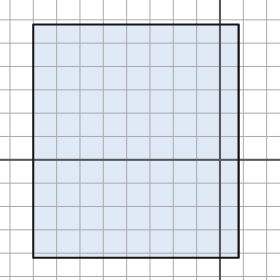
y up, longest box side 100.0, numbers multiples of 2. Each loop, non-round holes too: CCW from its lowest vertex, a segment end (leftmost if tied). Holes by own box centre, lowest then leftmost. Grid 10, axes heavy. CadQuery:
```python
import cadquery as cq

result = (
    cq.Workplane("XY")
    .moveTo(-80.0, -42.0)
    .lineTo(8.0, -42.0)
    .lineTo(8.0, 58.0)
    .lineTo(-80.0, 58.0)
    .close()
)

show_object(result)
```